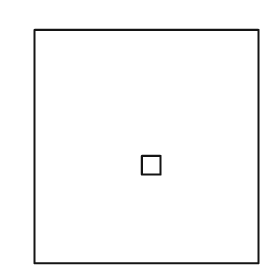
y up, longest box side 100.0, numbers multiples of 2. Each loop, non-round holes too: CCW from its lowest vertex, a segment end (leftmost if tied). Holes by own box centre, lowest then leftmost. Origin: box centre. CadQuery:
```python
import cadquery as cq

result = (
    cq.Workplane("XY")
    .moveTo(-48.0, -50.0)
    .lineTo(48.0, -50.0)
    .lineTo(48.0, 50.0)
    .lineTo(-48.0, 50.0)
    .close()
    .moveTo(-2.0, -12.0)
    .lineTo(6.0, -12.0)
    .lineTo(6.0, -4.0)
    .lineTo(-2.0, -4.0)
    .close()
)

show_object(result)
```